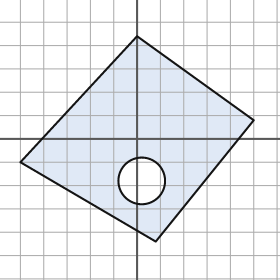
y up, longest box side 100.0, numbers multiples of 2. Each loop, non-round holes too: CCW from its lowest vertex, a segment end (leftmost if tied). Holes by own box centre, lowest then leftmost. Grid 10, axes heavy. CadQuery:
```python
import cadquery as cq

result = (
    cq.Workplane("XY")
    .moveTo(8.0, -44.0)
    .lineTo(50.0, 8.0)
    .lineTo(0.0, 44.0)
    .lineTo(-50.0, -10.0)
    .close()
    .moveTo(2.0, -18.0)
    .circle(10.0)
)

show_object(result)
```